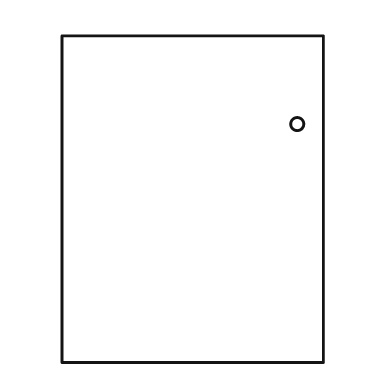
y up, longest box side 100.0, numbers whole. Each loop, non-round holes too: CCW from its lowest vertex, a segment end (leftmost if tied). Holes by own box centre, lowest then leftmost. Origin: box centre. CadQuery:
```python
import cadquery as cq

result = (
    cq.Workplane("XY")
    .moveTo(-40.0, -50.0)
    .lineTo(40.0, -50.0)
    .lineTo(40.0, 50.0)
    .lineTo(-40.0, 50.0)
    .close()
    .moveTo(32.0, 23.0)
    .circle(2.0)
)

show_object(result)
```